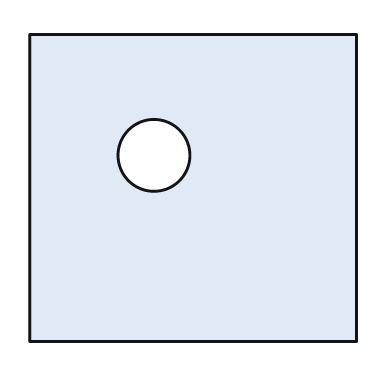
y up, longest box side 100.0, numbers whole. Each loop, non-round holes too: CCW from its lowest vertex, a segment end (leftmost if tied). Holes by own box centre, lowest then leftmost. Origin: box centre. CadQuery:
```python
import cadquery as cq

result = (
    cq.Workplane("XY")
    .moveTo(-50.0, -47.0)
    .lineTo(50.0, -47.0)
    .lineTo(50.0, 47.0)
    .lineTo(-50.0, 47.0)
    .close()
    .moveTo(-12.0, 10.0)
    .circle(11.0)
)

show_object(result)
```